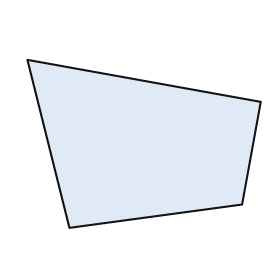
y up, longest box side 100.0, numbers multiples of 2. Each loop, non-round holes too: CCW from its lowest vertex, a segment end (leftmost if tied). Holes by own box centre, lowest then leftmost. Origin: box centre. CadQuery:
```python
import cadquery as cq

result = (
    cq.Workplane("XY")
    .moveTo(-32.0, -36.0)
    .lineTo(42.0, -26.0)
    .lineTo(50.0, 18.0)
    .lineTo(-50.0, 36.0)
    .close()
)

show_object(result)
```